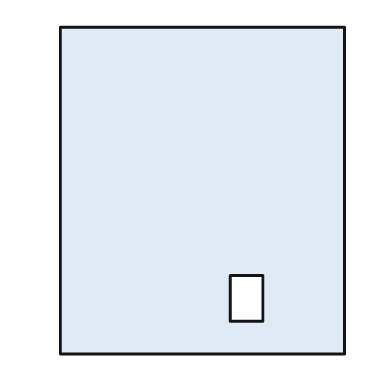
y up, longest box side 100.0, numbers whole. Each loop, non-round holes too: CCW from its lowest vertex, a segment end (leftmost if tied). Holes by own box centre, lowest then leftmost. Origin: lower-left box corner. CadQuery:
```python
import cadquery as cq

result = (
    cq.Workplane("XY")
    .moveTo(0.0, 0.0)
    .lineTo(87.0, 0.0)
    .lineTo(87.0, 100.0)
    .lineTo(0.0, 100.0)
    .close()
    .moveTo(52.0, 10.0)
    .lineTo(62.0, 10.0)
    .lineTo(62.0, 24.0)
    .lineTo(52.0, 24.0)
    .close()
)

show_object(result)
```